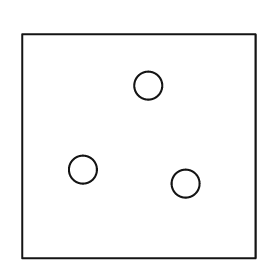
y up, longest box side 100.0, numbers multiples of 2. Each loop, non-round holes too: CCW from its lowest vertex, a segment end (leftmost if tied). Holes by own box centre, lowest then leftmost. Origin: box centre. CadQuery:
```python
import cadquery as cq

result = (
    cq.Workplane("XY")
    .moveTo(-50.0, -48.0)
    .lineTo(50.0, -48.0)
    .lineTo(50.0, 48.0)
    .lineTo(-50.0, 48.0)
    .close()
    .moveTo(20.0, -16.0)
    .circle(6.0)
    .moveTo(-24.0, -10.0)
    .circle(6.0)
    .moveTo(4.0, 26.0)
    .circle(6.0)
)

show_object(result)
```